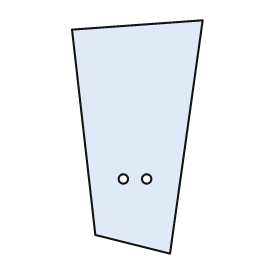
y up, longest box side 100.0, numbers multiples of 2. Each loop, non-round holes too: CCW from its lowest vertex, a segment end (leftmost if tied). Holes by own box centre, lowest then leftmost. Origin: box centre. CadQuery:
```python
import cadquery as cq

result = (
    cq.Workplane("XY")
    .moveTo(14.0, -50.0)
    .lineTo(28.0, 50.0)
    .lineTo(-28.0, 46.0)
    .lineTo(-18.0, -42.0)
    .close()
    .moveTo(-6.0, -18.0)
    .circle(2.0)
    .moveTo(4.0, -18.0)
    .circle(2.0)
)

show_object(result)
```